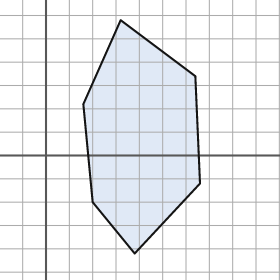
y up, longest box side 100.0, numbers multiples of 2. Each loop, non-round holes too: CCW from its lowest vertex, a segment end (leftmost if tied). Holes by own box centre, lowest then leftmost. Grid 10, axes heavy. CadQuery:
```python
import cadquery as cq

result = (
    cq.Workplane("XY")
    .moveTo(38.0, -42.0)
    .lineTo(66.0, -12.0)
    .lineTo(64.0, 34.0)
    .lineTo(32.0, 58.0)
    .lineTo(16.0, 22.0)
    .lineTo(20.0, -20.0)
    .close()
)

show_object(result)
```